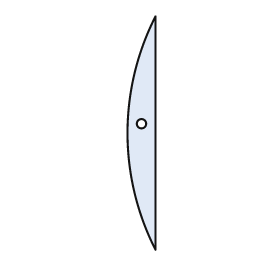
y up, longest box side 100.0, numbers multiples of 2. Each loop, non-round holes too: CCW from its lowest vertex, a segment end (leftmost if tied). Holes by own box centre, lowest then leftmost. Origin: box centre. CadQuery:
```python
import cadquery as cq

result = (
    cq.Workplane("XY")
    .moveTo(6.0, -50.0)
    .lineTo(6.0, 50.0)
    .threePointArc((-6.0, 0.0), (6.0, -50.0))
    .close()
    .moveTo(0.0, 4.0)
    .circle(2.0)
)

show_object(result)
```